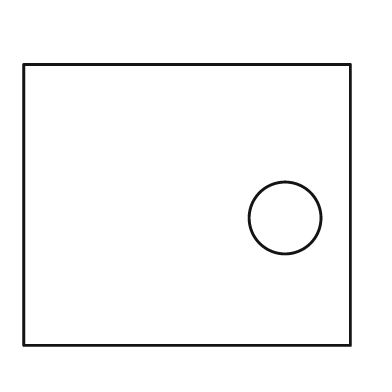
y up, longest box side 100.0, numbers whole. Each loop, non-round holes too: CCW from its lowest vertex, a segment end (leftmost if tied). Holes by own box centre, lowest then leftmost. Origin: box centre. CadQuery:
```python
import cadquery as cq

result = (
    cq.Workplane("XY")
    .moveTo(-50.0, -43.0)
    .lineTo(50.0, -43.0)
    .lineTo(50.0, 43.0)
    .lineTo(-50.0, 43.0)
    .close()
    .moveTo(30.0, -4.0)
    .circle(11.0)
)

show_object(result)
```